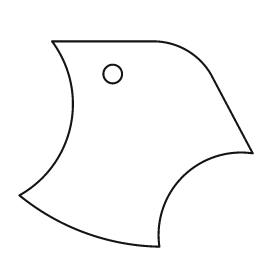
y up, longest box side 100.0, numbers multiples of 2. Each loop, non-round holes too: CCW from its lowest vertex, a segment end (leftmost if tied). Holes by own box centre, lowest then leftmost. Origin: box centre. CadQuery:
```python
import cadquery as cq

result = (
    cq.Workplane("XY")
    .moveTo(10.0, -44.0)
    .threePointArc((20.0, -14.0), (50.0, -4.0))
    .lineTo(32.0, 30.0)
    .threePointArc((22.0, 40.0), (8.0, 44.0))
    .lineTo(-36.0, 44.0)
    .threePointArc((-28.0, 8.0), (-50.0, -22.0))
    .threePointArc((-22.0, -38.0), (10.0, -44.0))
    .close()
    .moveTo(-10.0, 30.0)
    .circle(4.0)
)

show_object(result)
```